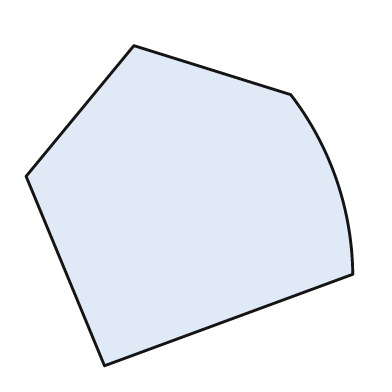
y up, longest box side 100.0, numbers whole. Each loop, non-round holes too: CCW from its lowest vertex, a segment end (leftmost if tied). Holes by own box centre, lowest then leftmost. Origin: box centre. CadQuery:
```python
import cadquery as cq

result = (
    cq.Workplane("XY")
    .moveTo(-26.0, -49.0)
    .lineTo(50.0, -21.0)
    .threePointArc((45.0, 8.0), (31.0, 34.0))
    .lineTo(-17.0, 49.0)
    .lineTo(-50.0, 9.0)
    .close()
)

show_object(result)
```